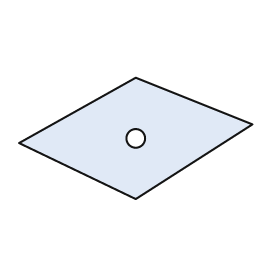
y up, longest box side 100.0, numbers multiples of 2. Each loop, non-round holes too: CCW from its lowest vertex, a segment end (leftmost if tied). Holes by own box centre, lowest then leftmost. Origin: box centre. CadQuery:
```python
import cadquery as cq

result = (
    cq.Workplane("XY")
    .moveTo(0.0, -26.0)
    .lineTo(50.0, 6.0)
    .lineTo(0.0, 26.0)
    .lineTo(-50.0, -2.0)
    .close()
    .moveTo(0.0, 0.0)
    .circle(4.0)
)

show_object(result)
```